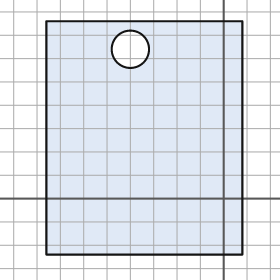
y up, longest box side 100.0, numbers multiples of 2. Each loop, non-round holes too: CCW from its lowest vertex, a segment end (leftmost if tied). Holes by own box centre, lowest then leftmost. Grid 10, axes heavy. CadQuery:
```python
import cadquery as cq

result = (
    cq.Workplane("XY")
    .moveTo(-76.0, -24.0)
    .lineTo(8.0, -24.0)
    .lineTo(8.0, 76.0)
    .lineTo(-76.0, 76.0)
    .close()
    .moveTo(-40.0, 64.0)
    .circle(8.0)
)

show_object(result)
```